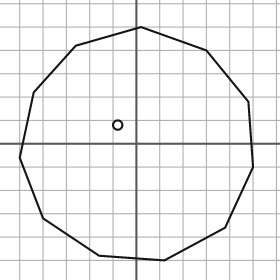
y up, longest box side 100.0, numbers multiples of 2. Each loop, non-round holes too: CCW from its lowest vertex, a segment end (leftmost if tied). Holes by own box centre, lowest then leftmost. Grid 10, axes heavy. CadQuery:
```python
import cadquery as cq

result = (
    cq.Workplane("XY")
    .moveTo(12.0, -50.0)
    .lineTo(38.0, -36.0)
    .lineTo(50.0, -10.0)
    .lineTo(48.0, 18.0)
    .lineTo(30.0, 40.0)
    .lineTo(2.0, 50.0)
    .lineTo(-26.0, 42.0)
    .lineTo(-44.0, 22.0)
    .lineTo(-50.0, -6.0)
    .lineTo(-40.0, -32.0)
    .lineTo(-16.0, -48.0)
    .close()
    .moveTo(-8.0, 8.0)
    .circle(2.0)
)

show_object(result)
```